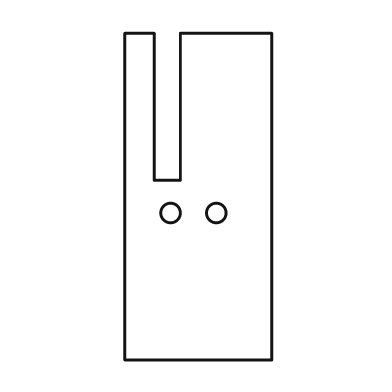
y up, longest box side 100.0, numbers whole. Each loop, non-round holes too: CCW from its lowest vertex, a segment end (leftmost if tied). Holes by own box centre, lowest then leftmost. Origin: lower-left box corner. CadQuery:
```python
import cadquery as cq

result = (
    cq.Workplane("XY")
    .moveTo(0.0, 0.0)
    .lineTo(45.0, 0.0)
    .lineTo(45.0, 100.0)
    .lineTo(17.0, 100.0)
    .lineTo(17.0, 55.0)
    .lineTo(9.0, 55.0)
    .lineTo(9.0, 100.0)
    .lineTo(0.0, 100.0)
    .close()
    .moveTo(14.0, 45.0)
    .circle(3.0)
    .moveTo(28.0, 45.0)
    .circle(3.0)
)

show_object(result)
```